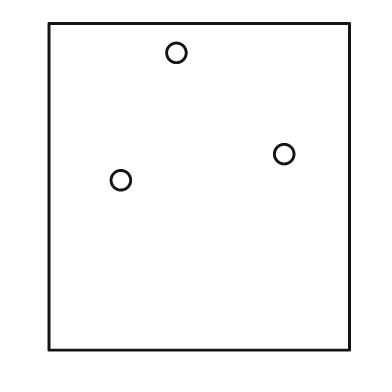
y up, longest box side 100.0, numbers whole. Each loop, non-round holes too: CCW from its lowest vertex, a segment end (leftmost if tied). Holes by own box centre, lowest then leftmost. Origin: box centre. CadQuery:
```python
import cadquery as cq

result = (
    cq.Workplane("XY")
    .moveTo(-46.0, -50.0)
    .lineTo(46.0, -50.0)
    .lineTo(46.0, 50.0)
    .lineTo(-46.0, 50.0)
    .close()
    .moveTo(-24.0, 2.0)
    .circle(3.0)
    .moveTo(26.0, 10.0)
    .circle(3.0)
    .moveTo(-7.0, 41.0)
    .circle(3.0)
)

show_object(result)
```